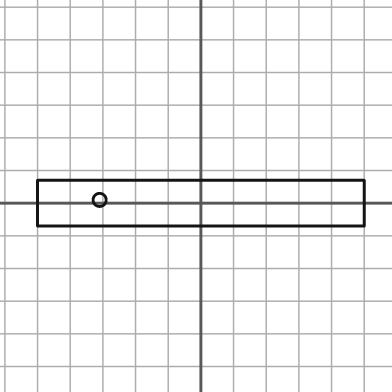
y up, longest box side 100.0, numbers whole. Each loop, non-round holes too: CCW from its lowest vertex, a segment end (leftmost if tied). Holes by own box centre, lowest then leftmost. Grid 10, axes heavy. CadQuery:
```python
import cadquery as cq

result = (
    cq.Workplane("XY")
    .moveTo(-50.0, -7.0)
    .lineTo(50.0, -7.0)
    .lineTo(50.0, 7.0)
    .lineTo(-50.0, 7.0)
    .close()
    .moveTo(-31.0, 1.0)
    .circle(2.0)
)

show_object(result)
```